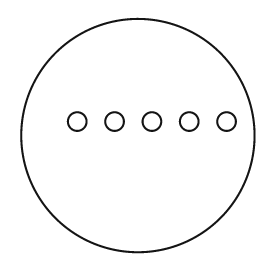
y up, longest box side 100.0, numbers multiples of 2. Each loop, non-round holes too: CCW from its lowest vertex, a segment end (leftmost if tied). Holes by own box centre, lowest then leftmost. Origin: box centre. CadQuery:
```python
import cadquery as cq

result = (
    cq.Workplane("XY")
    .moveTo(0.0, 0.0)
    .circle(50.0)
    .moveTo(-26.0, 6.0)
    .circle(4.0)
    .moveTo(-10.0, 6.0)
    .circle(4.0)
    .moveTo(6.0, 6.0)
    .circle(4.0)
    .moveTo(22.0, 6.0)
    .circle(4.0)
    .moveTo(38.0, 6.0)
    .circle(4.0)
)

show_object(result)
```